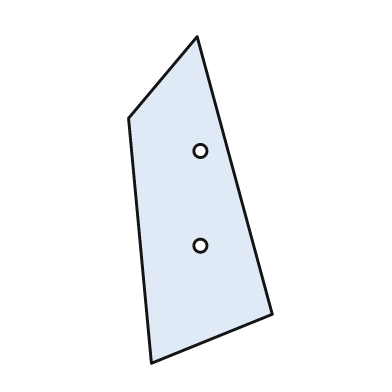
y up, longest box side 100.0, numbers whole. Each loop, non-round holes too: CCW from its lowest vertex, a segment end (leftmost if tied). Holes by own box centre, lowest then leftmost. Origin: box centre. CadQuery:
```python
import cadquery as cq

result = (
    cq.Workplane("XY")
    .moveTo(-15.0, -50.0)
    .lineTo(22.0, -35.0)
    .lineTo(-1.0, 50.0)
    .lineTo(-22.0, 25.0)
    .close()
    .moveTo(0.0, -14.0)
    .circle(2.0)
    .moveTo(0.0, 15.0)
    .circle(2.0)
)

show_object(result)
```